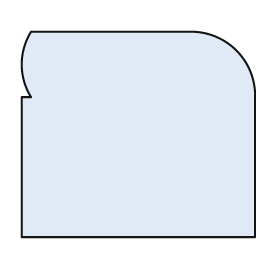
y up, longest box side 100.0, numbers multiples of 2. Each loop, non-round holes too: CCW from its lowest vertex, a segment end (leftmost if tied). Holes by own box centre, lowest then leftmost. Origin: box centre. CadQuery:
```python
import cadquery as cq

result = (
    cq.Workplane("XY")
    .moveTo(-50.0, -44.0)
    .lineTo(50.0, -44.0)
    .lineTo(50.0, 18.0)
    .threePointArc((42.0, 36.0), (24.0, 44.0))
    .lineTo(-46.0, 44.0)
    .threePointArc((-50.0, 30.0), (-46.0, 16.0))
    .lineTo(-50.0, 16.0)
    .close()
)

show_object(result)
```